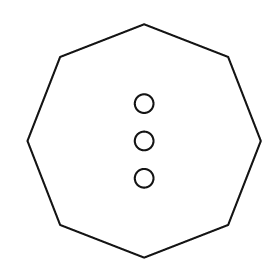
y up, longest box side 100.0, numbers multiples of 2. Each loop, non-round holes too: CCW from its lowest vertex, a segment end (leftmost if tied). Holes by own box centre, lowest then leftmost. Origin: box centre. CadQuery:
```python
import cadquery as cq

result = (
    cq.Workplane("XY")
    .moveTo(0.0, -50.0)
    .lineTo(36.0, -36.0)
    .lineTo(50.0, 0.0)
    .lineTo(36.0, 36.0)
    .lineTo(0.0, 50.0)
    .lineTo(-36.0, 36.0)
    .lineTo(-50.0, 0.0)
    .lineTo(-36.0, -36.0)
    .close()
    .moveTo(0.0, -16.0)
    .circle(4.0)
    .moveTo(0.0, 0.0)
    .circle(4.0)
    .moveTo(0.0, 16.0)
    .circle(4.0)
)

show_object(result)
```